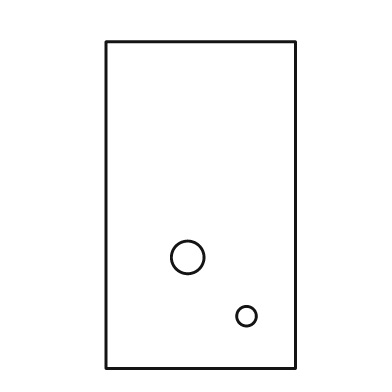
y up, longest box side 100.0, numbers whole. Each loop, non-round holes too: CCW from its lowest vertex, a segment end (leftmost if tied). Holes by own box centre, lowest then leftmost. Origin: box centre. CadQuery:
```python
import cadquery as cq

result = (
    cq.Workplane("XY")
    .moveTo(-29.0, -50.0)
    .lineTo(29.0, -50.0)
    .lineTo(29.0, 50.0)
    .lineTo(-29.0, 50.0)
    .close()
    .moveTo(14.0, -34.0)
    .circle(3.0)
    .moveTo(-4.0, -16.0)
    .circle(5.0)
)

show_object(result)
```